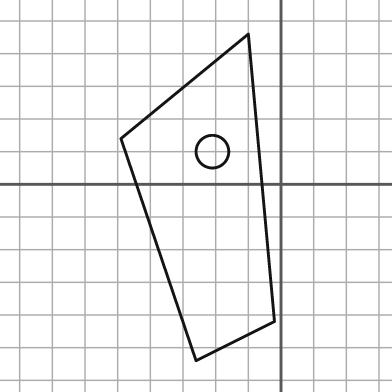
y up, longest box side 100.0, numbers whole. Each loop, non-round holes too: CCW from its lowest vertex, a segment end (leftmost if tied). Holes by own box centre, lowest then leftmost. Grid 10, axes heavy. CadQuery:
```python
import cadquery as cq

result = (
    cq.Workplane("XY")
    .moveTo(-26.0, -54.0)
    .lineTo(-2.0, -42.0)
    .lineTo(-10.0, 46.0)
    .lineTo(-49.0, 14.0)
    .close()
    .moveTo(-21.0, 10.0)
    .circle(5.0)
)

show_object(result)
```